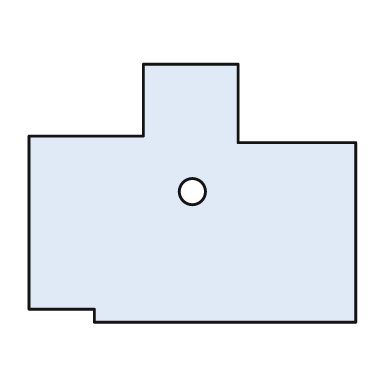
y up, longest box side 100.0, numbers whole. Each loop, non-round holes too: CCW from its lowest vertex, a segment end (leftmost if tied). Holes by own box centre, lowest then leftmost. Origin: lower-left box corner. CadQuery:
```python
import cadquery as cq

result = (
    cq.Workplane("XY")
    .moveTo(20.0, 0.0)
    .lineTo(100.0, 0.0)
    .lineTo(100.0, 55.0)
    .lineTo(64.0, 55.0)
    .lineTo(64.0, 79.0)
    .lineTo(35.0, 79.0)
    .lineTo(35.0, 57.0)
    .lineTo(0.0, 57.0)
    .lineTo(0.0, 4.0)
    .lineTo(20.0, 4.0)
    .close()
    .moveTo(50.0, 40.0)
    .circle(4.0)
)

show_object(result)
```